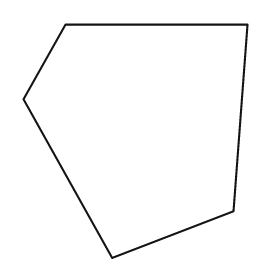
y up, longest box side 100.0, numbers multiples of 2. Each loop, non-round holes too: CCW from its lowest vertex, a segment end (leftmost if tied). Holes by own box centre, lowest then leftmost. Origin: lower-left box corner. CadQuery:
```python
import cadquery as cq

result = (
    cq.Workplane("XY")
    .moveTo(38.0, 0.0)
    .lineTo(90.0, 20.0)
    .lineTo(96.0, 100.0)
    .lineTo(18.0, 100.0)
    .lineTo(0.0, 68.0)
    .close()
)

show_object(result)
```